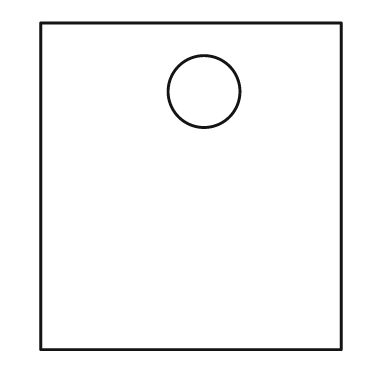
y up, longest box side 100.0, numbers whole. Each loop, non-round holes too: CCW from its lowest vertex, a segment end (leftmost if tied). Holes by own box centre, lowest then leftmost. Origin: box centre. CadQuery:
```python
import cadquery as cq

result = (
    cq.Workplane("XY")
    .moveTo(-46.0, -50.0)
    .lineTo(46.0, -50.0)
    .lineTo(46.0, 50.0)
    .lineTo(-46.0, 50.0)
    .close()
    .moveTo(4.0, 29.0)
    .circle(11.0)
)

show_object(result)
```